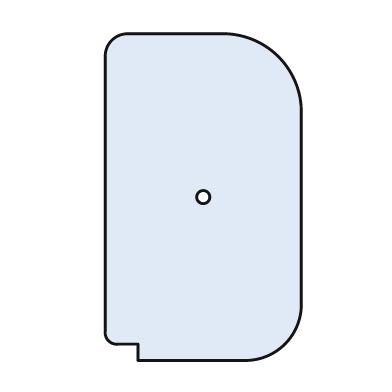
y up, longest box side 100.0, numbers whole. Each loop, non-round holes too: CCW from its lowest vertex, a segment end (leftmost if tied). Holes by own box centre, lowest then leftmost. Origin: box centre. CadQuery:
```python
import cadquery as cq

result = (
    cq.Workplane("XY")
    .moveTo(-20.0, -50.0)
    .lineTo(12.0, -50.0)
    .threePointArc((25.0, -45.0), (30.0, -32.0))
    .lineTo(30.0, 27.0)
    .threePointArc((23.0, 43.0), (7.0, 50.0))
    .lineTo(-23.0, 50.0)
    .threePointArc((-28.0, 48.0), (-30.0, 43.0))
    .lineTo(-30.0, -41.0)
    .threePointArc((-29.0, -44.0), (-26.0, -45.0))
    .lineTo(-20.0, -45.0)
    .close()
    .moveTo(0.0, 0.0)
    .circle(2.0)
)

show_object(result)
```